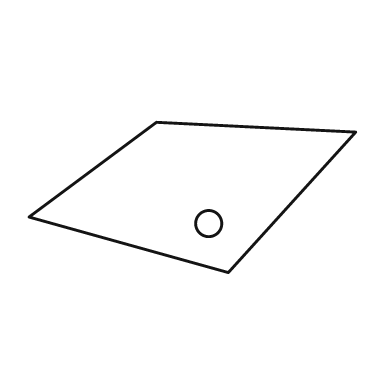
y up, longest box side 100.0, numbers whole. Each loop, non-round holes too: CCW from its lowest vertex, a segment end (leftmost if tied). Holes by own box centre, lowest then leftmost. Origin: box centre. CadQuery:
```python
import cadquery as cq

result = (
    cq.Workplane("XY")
    .moveTo(11.0, -23.0)
    .lineTo(50.0, 20.0)
    .lineTo(-11.0, 23.0)
    .lineTo(-50.0, -6.0)
    .close()
    .moveTo(5.0, -8.0)
    .circle(4.0)
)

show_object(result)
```